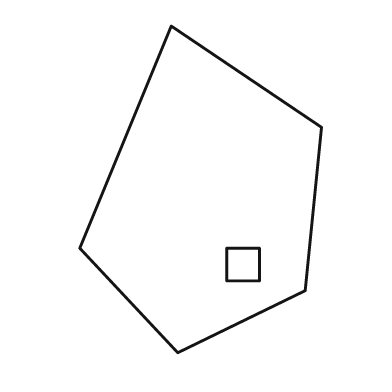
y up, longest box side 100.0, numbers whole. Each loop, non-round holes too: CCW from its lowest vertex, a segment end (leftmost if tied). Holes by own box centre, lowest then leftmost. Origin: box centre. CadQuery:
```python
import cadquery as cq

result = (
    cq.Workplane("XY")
    .moveTo(-7.0, -50.0)
    .lineTo(32.0, -31.0)
    .lineTo(37.0, 19.0)
    .lineTo(-9.0, 50.0)
    .lineTo(-37.0, -18.0)
    .close()
    .moveTo(8.0, -28.0)
    .lineTo(18.0, -28.0)
    .lineTo(18.0, -18.0)
    .lineTo(8.0, -18.0)
    .close()
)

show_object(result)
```